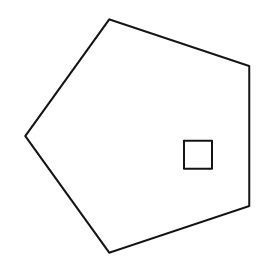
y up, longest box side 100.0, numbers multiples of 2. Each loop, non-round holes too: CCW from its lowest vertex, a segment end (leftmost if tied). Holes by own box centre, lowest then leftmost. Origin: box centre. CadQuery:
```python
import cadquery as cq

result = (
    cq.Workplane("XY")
    .moveTo(-12.0, -50.0)
    .lineTo(48.0, -30.0)
    .lineTo(48.0, 30.0)
    .lineTo(-12.0, 50.0)
    .lineTo(-48.0, 0.0)
    .close()
    .moveTo(20.0, -14.0)
    .lineTo(32.0, -14.0)
    .lineTo(32.0, -2.0)
    .lineTo(20.0, -2.0)
    .close()
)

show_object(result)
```